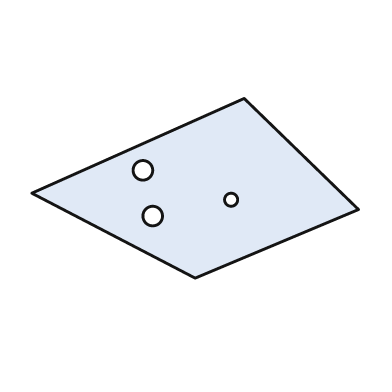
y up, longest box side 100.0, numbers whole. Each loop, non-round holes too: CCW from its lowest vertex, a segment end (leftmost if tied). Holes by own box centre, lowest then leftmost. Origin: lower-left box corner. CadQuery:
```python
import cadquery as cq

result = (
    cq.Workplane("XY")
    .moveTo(50.0, 0.0)
    .lineTo(100.0, 21.0)
    .lineTo(65.0, 55.0)
    .lineTo(0.0, 26.0)
    .close()
    .moveTo(37.0, 19.0)
    .circle(3.0)
    .moveTo(61.0, 24.0)
    .circle(2.0)
    .moveTo(34.0, 33.0)
    .circle(3.0)
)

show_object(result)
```